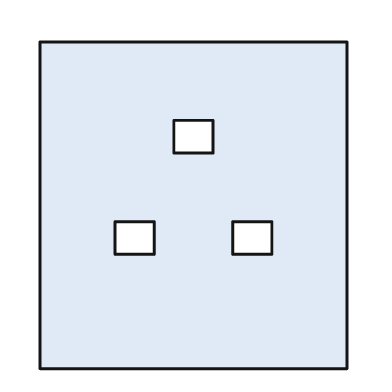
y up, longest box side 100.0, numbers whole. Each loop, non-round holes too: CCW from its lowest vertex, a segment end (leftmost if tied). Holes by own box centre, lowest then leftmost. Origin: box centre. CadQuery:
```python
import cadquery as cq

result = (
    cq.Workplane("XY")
    .moveTo(-47.0, -50.0)
    .lineTo(47.0, -50.0)
    .lineTo(47.0, 50.0)
    .lineTo(-47.0, 50.0)
    .close()
    .moveTo(-24.0, -15.0)
    .lineTo(-12.0, -15.0)
    .lineTo(-12.0, -5.0)
    .lineTo(-24.0, -5.0)
    .close()
    .moveTo(12.0, -15.0)
    .lineTo(24.0, -15.0)
    .lineTo(24.0, -5.0)
    .lineTo(12.0, -5.0)
    .close()
    .moveTo(-6.0, 16.0)
    .lineTo(6.0, 16.0)
    .lineTo(6.0, 26.0)
    .lineTo(-6.0, 26.0)
    .close()
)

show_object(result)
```